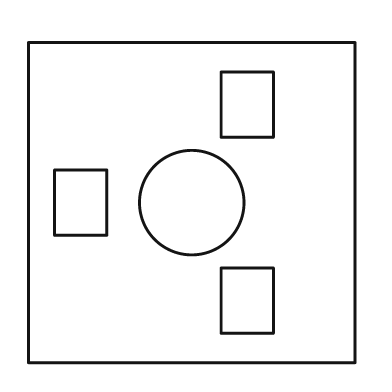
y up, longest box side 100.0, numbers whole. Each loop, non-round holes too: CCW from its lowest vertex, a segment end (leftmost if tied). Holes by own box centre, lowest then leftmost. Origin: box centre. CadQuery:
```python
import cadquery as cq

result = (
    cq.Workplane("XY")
    .moveTo(-50.0, -49.0)
    .lineTo(50.0, -49.0)
    .lineTo(50.0, 49.0)
    .lineTo(-50.0, 49.0)
    .close()
    .moveTo(9.0, -40.0)
    .lineTo(25.0, -40.0)
    .lineTo(25.0, -20.0)
    .lineTo(9.0, -20.0)
    .close()
    .moveTo(-42.0, -10.0)
    .lineTo(-26.0, -10.0)
    .lineTo(-26.0, 10.0)
    .lineTo(-42.0, 10.0)
    .close()
    .moveTo(0.0, 0.0)
    .circle(16.0)
    .moveTo(9.0, 20.0)
    .lineTo(25.0, 20.0)
    .lineTo(25.0, 40.0)
    .lineTo(9.0, 40.0)
    .close()
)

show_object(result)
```